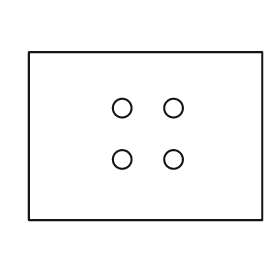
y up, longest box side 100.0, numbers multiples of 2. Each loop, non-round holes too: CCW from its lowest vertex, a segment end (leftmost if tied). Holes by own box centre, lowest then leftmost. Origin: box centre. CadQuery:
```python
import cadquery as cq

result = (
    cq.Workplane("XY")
    .moveTo(-50.0, -36.0)
    .lineTo(50.0, -36.0)
    .lineTo(50.0, 36.0)
    .lineTo(-50.0, 36.0)
    .close()
    .moveTo(-10.0, -10.0)
    .circle(4.0)
    .moveTo(12.0, -10.0)
    .circle(4.0)
    .moveTo(-10.0, 12.0)
    .circle(4.0)
    .moveTo(12.0, 12.0)
    .circle(4.0)
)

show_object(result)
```